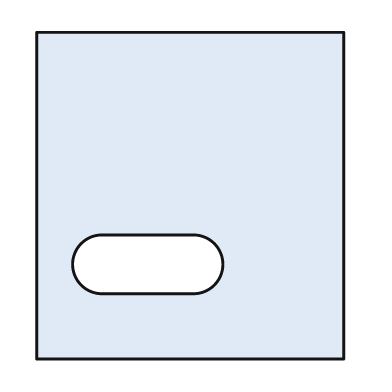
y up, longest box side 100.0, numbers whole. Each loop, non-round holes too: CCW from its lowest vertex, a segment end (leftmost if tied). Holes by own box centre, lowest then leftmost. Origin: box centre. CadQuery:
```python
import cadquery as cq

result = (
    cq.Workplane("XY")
    .moveTo(-47.0, -50.0)
    .lineTo(47.0, -50.0)
    .lineTo(47.0, 50.0)
    .lineTo(-47.0, 50.0)
    .close()
    .moveTo(-27.0, -30.0)
    .lineTo(1.0, -30.0)
    .threePointArc((10.0, -21.0), (1.0, -12.0))
    .lineTo(-27.0, -12.0)
    .threePointArc((-36.0, -21.0), (-27.0, -30.0))
    .close()
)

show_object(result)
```